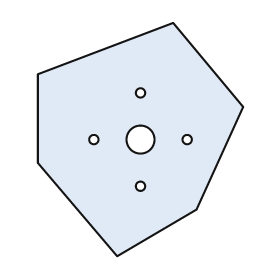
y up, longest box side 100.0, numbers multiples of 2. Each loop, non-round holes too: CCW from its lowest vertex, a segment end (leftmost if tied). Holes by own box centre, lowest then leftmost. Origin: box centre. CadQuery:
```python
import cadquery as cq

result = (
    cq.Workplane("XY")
    .moveTo(-10.0, -50.0)
    .lineTo(24.0, -30.0)
    .lineTo(44.0, 14.0)
    .lineTo(14.0, 50.0)
    .lineTo(-44.0, 28.0)
    .lineTo(-44.0, -10.0)
    .close()
    .moveTo(0.0, -20.0)
    .circle(2.0)
    .moveTo(-20.0, 0.0)
    .circle(2.0)
    .moveTo(0.0, 0.0)
    .circle(6.0)
    .moveTo(20.0, 0.0)
    .circle(2.0)
    .moveTo(0.0, 20.0)
    .circle(2.0)
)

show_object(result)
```